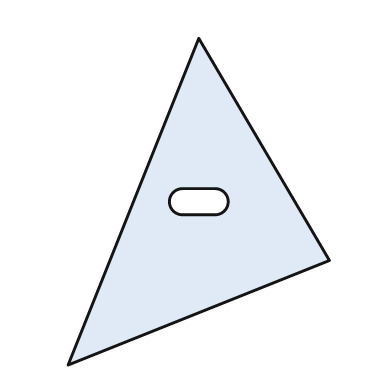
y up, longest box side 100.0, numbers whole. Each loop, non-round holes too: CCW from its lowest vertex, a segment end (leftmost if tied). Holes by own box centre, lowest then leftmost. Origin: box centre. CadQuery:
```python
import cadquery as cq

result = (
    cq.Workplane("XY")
    .moveTo(-40.0, -50.0)
    .lineTo(40.0, -18.0)
    .lineTo(0.0, 50.0)
    .close()
    .moveTo(-5.0, -4.0)
    .lineTo(5.0, -4.0)
    .threePointArc((9.0, 0.0), (5.0, 4.0))
    .lineTo(-5.0, 4.0)
    .threePointArc((-9.0, 0.0), (-5.0, -4.0))
    .close()
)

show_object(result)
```